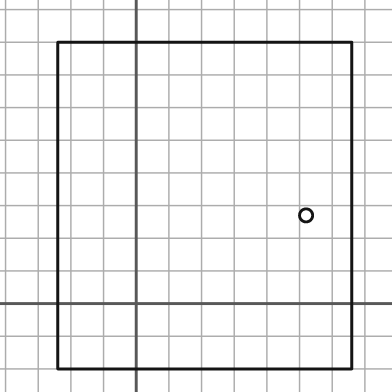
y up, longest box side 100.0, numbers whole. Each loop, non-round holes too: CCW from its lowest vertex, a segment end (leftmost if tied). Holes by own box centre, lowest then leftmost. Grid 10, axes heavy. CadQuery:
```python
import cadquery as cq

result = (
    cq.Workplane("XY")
    .moveTo(-24.0, -20.0)
    .lineTo(66.0, -20.0)
    .lineTo(66.0, 80.0)
    .lineTo(-24.0, 80.0)
    .close()
    .moveTo(52.0, 27.0)
    .circle(2.0)
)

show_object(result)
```